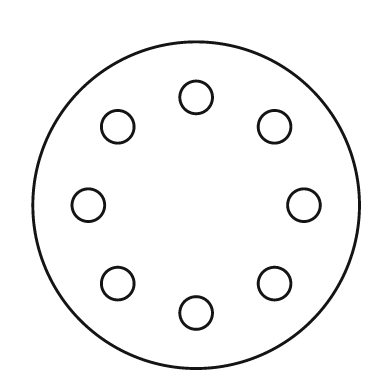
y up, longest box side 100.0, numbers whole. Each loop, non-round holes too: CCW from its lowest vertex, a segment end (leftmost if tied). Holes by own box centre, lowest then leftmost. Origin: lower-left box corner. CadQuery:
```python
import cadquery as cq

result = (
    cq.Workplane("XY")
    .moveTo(50.0, 50.0)
    .circle(50.0)
    .moveTo(50.0, 17.0)
    .circle(5.0)
    .moveTo(26.0, 26.0)
    .circle(5.0)
    .moveTo(74.0, 26.0)
    .circle(5.0)
    .moveTo(17.0, 50.0)
    .circle(5.0)
    .moveTo(83.0, 50.0)
    .circle(5.0)
    .moveTo(26.0, 74.0)
    .circle(5.0)
    .moveTo(74.0, 74.0)
    .circle(5.0)
    .moveTo(50.0, 83.0)
    .circle(5.0)
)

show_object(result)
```